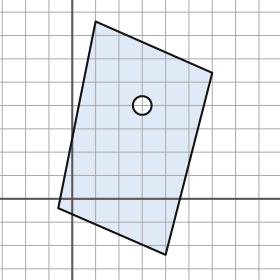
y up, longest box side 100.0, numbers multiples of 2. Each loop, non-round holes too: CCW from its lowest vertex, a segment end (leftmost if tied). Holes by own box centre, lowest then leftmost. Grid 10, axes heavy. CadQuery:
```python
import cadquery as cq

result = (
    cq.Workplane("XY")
    .moveTo(40.0, -24.0)
    .lineTo(60.0, 54.0)
    .lineTo(10.0, 76.0)
    .lineTo(-6.0, -4.0)
    .close()
    .moveTo(30.0, 40.0)
    .circle(4.0)
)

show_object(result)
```